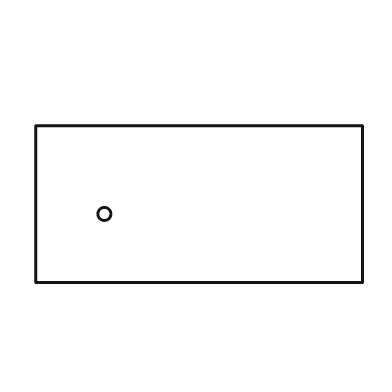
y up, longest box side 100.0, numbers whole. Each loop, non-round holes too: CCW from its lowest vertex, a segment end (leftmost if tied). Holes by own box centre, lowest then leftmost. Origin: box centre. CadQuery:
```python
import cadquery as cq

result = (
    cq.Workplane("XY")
    .moveTo(-50.0, -24.0)
    .lineTo(50.0, -24.0)
    .lineTo(50.0, 24.0)
    .lineTo(-50.0, 24.0)
    .close()
    .moveTo(-29.0, -3.0)
    .circle(2.0)
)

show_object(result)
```